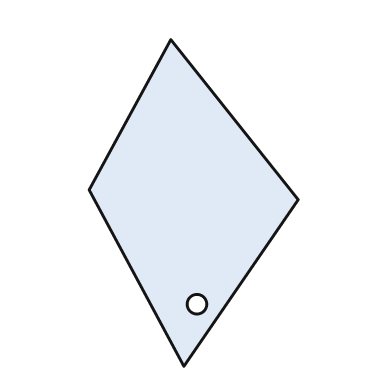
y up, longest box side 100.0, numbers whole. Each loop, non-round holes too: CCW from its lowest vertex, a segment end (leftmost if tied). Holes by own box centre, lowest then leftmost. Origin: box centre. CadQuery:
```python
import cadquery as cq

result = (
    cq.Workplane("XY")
    .moveTo(-3.0, -50.0)
    .lineTo(32.0, 1.0)
    .lineTo(-7.0, 50.0)
    .lineTo(-32.0, 4.0)
    .close()
    .moveTo(1.0, -31.0)
    .circle(3.0)
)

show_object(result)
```